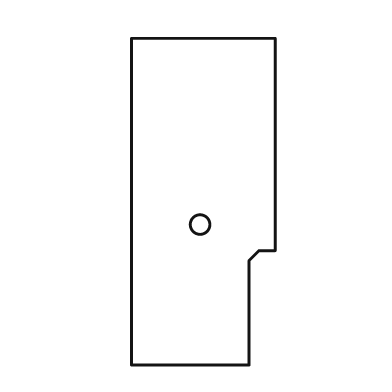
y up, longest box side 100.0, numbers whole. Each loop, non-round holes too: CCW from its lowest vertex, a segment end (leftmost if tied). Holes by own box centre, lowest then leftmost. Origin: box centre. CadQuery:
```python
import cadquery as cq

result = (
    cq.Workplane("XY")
    .moveTo(-22.0, -50.0)
    .lineTo(14.0, -50.0)
    .lineTo(14.0, -18.0)
    .lineTo(17.0, -15.0)
    .lineTo(22.0, -15.0)
    .lineTo(22.0, 50.0)
    .lineTo(-22.0, 50.0)
    .close()
    .moveTo(-1.0, -7.0)
    .circle(3.0)
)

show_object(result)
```